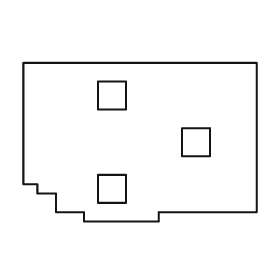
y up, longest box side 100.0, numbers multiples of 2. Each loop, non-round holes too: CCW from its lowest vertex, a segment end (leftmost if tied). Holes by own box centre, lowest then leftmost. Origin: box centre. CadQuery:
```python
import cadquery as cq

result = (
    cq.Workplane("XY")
    .moveTo(-24.0, -34.0)
    .lineTo(8.0, -34.0)
    .lineTo(8.0, -30.0)
    .lineTo(50.0, -30.0)
    .lineTo(50.0, 34.0)
    .lineTo(-50.0, 34.0)
    .lineTo(-50.0, -18.0)
    .lineTo(-44.0, -18.0)
    .lineTo(-44.0, -22.0)
    .lineTo(-36.0, -22.0)
    .lineTo(-36.0, -30.0)
    .lineTo(-24.0, -30.0)
    .close()
    .moveTo(-18.0, -26.0)
    .lineTo(-6.0, -26.0)
    .lineTo(-6.0, -14.0)
    .lineTo(-18.0, -14.0)
    .close()
    .moveTo(18.0, -6.0)
    .lineTo(30.0, -6.0)
    .lineTo(30.0, 6.0)
    .lineTo(18.0, 6.0)
    .close()
    .moveTo(-18.0, 14.0)
    .lineTo(-6.0, 14.0)
    .lineTo(-6.0, 26.0)
    .lineTo(-18.0, 26.0)
    .close()
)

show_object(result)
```